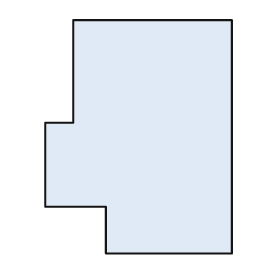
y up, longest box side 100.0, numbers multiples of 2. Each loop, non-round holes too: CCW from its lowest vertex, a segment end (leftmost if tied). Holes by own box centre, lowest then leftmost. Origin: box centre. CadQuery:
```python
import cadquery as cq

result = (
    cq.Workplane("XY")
    .moveTo(-14.0, -50.0)
    .lineTo(40.0, -50.0)
    .lineTo(40.0, 50.0)
    .lineTo(-28.0, 50.0)
    .lineTo(-28.0, 6.0)
    .lineTo(-40.0, 6.0)
    .lineTo(-40.0, -30.0)
    .lineTo(-14.0, -30.0)
    .close()
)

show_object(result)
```